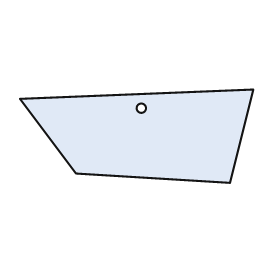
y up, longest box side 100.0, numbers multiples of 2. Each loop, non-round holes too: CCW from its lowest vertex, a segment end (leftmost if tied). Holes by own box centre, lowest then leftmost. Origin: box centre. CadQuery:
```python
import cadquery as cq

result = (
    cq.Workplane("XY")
    .moveTo(40.0, -20.0)
    .lineTo(50.0, 20.0)
    .lineTo(-50.0, 16.0)
    .lineTo(-26.0, -16.0)
    .close()
    .moveTo(2.0, 12.0)
    .circle(2.0)
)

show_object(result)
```